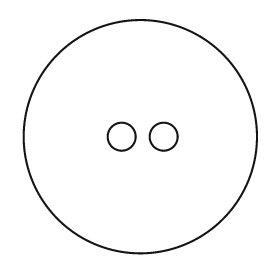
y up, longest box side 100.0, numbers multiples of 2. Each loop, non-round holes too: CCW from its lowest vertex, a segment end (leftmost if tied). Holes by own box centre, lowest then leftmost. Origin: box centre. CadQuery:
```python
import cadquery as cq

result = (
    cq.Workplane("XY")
    .moveTo(0.0, 0.0)
    .circle(50.0)
    .moveTo(-8.0, 0.0)
    .circle(6.0)
    .moveTo(10.0, 0.0)
    .circle(6.0)
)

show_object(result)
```